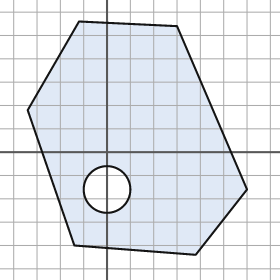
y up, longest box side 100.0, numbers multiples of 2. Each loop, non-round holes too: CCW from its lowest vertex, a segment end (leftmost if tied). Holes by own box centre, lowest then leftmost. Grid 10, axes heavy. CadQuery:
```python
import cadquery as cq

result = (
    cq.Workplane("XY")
    .moveTo(38.0, -44.0)
    .lineTo(60.0, -16.0)
    .lineTo(30.0, 54.0)
    .lineTo(-12.0, 56.0)
    .lineTo(-34.0, 18.0)
    .lineTo(-14.0, -40.0)
    .close()
    .moveTo(0.0, -16.0)
    .circle(10.0)
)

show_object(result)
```